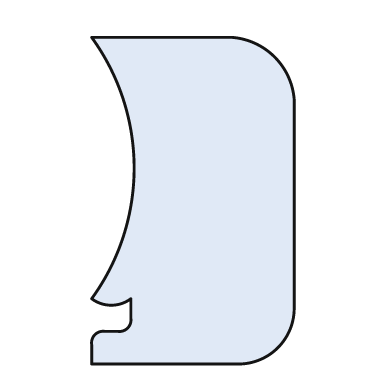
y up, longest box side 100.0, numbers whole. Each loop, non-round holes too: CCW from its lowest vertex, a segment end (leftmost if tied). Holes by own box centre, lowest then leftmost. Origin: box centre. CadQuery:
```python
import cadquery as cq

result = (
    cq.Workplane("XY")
    .moveTo(-31.0, -50.0)
    .lineTo(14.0, -50.0)
    .threePointArc((26.0, -45.0), (31.0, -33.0))
    .lineTo(31.0, 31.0)
    .threePointArc((25.0, 44.0), (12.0, 50.0))
    .lineTo(-31.0, 50.0)
    .threePointArc((-18.0, 10.0), (-31.0, -30.0))
    .threePointArc((-25.0, -32.0), (-19.0, -30.0))
    .lineTo(-19.0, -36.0)
    .threePointArc((-20.0, -39.0), (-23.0, -40.0))
    .lineTo(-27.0, -40.0)
    .threePointArc((-30.0, -41.0), (-31.0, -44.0))
    .close()
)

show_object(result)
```